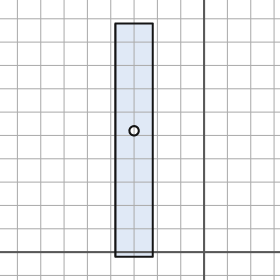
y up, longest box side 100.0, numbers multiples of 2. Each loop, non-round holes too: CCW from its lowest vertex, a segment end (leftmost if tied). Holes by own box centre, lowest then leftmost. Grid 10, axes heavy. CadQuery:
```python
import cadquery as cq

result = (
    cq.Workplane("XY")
    .moveTo(-38.0, -2.0)
    .lineTo(-22.0, -2.0)
    .lineTo(-22.0, 98.0)
    .lineTo(-38.0, 98.0)
    .close()
    .moveTo(-30.0, 52.0)
    .circle(2.0)
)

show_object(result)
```